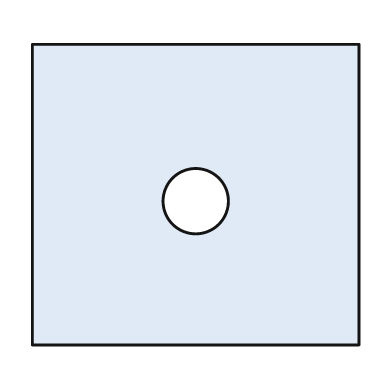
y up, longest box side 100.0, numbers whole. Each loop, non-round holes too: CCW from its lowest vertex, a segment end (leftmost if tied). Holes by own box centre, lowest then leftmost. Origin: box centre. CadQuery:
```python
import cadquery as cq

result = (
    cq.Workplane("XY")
    .moveTo(-50.0, -46.0)
    .lineTo(50.0, -46.0)
    .lineTo(50.0, 46.0)
    .lineTo(-50.0, 46.0)
    .close()
    .moveTo(0.0, -2.0)
    .circle(10.0)
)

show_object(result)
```